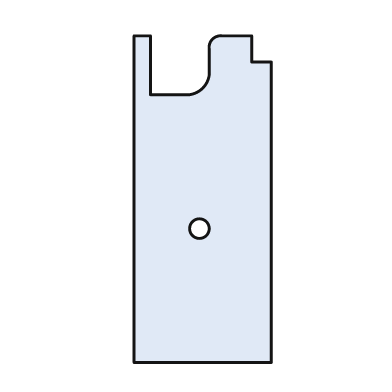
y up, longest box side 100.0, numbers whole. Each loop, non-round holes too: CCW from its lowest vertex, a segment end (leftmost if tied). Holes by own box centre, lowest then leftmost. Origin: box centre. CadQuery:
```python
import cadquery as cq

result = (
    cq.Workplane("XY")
    .moveTo(-21.0, -50.0)
    .lineTo(21.0, -50.0)
    .lineTo(21.0, 42.0)
    .lineTo(15.0, 42.0)
    .lineTo(15.0, 50.0)
    .lineTo(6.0, 50.0)
    .threePointArc((3.0, 49.0), (2.0, 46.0))
    .lineTo(2.0, 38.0)
    .threePointArc((0.0, 34.0), (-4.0, 32.0))
    .lineTo(-16.0, 32.0)
    .lineTo(-16.0, 50.0)
    .lineTo(-21.0, 50.0)
    .close()
    .moveTo(-1.0, -9.0)
    .circle(3.0)
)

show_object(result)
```